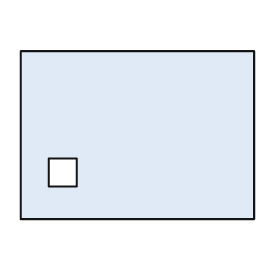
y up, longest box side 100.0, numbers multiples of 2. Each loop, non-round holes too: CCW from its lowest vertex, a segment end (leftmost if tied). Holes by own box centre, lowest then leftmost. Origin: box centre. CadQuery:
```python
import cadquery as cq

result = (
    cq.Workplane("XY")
    .moveTo(-50.0, -36.0)
    .lineTo(50.0, -36.0)
    .lineTo(50.0, 36.0)
    .lineTo(-50.0, 36.0)
    .close()
    .moveTo(-38.0, -22.0)
    .lineTo(-26.0, -22.0)
    .lineTo(-26.0, -10.0)
    .lineTo(-38.0, -10.0)
    .close()
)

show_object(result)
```